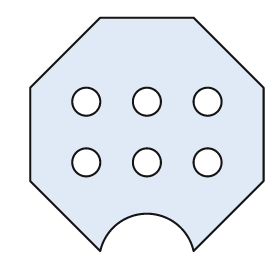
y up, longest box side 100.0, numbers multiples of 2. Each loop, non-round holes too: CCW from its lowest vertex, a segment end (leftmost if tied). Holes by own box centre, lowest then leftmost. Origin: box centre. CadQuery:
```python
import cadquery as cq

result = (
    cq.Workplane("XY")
    .moveTo(-20.0, -50.0)
    .threePointArc((0.0, -34.0), (20.0, -50.0))
    .lineTo(50.0, -20.0)
    .lineTo(50.0, 20.0)
    .lineTo(20.0, 50.0)
    .lineTo(-20.0, 50.0)
    .lineTo(-50.0, 20.0)
    .lineTo(-50.0, -20.0)
    .close()
    .moveTo(-26.0, -12.0)
    .circle(6.0)
    .moveTo(0.0, -12.0)
    .circle(6.0)
    .moveTo(26.0, -12.0)
    .circle(6.0)
    .moveTo(-26.0, 14.0)
    .circle(6.0)
    .moveTo(0.0, 14.0)
    .circle(6.0)
    .moveTo(26.0, 14.0)
    .circle(6.0)
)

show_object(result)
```